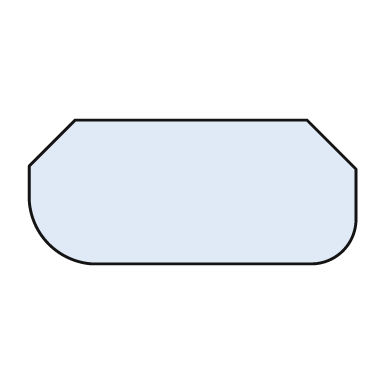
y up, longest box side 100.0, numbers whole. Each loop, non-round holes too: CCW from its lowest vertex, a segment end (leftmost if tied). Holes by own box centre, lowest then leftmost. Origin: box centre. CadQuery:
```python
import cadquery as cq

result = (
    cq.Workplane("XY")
    .moveTo(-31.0, -22.0)
    .lineTo(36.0, -22.0)
    .threePointArc((46.0, -18.0), (50.0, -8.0))
    .lineTo(50.0, 7.0)
    .lineTo(35.0, 22.0)
    .lineTo(-36.0, 22.0)
    .lineTo(-50.0, 8.0)
    .lineTo(-50.0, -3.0)
    .threePointArc((-44.0, -16.0), (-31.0, -22.0))
    .close()
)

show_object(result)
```